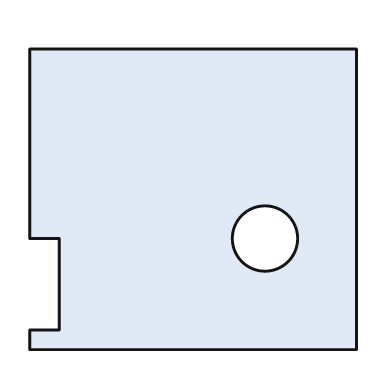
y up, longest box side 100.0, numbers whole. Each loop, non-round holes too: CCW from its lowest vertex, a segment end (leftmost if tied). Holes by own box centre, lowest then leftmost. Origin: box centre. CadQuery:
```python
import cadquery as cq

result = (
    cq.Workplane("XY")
    .moveTo(-50.0, -46.0)
    .lineTo(50.0, -46.0)
    .lineTo(50.0, 46.0)
    .lineTo(-50.0, 46.0)
    .lineTo(-50.0, -12.0)
    .lineTo(-41.0, -12.0)
    .lineTo(-41.0, -40.0)
    .lineTo(-50.0, -40.0)
    .close()
    .moveTo(22.0, -12.0)
    .circle(10.0)
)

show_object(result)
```